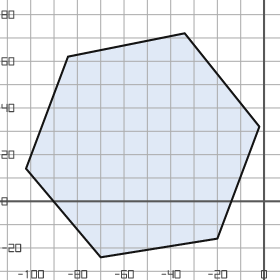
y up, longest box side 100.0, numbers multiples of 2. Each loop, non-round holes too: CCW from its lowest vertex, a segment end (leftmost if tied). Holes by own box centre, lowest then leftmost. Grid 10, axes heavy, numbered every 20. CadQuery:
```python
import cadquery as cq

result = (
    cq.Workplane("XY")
    .moveTo(-70.0, -24.0)
    .lineTo(-20.0, -16.0)
    .lineTo(-2.0, 32.0)
    .lineTo(-34.0, 72.0)
    .lineTo(-84.0, 62.0)
    .lineTo(-102.0, 14.0)
    .close()
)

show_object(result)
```